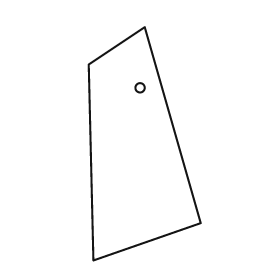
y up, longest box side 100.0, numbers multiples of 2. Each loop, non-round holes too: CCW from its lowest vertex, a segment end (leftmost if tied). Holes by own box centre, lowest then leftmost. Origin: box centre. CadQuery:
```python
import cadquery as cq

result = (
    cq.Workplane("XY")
    .moveTo(-22.0, -50.0)
    .lineTo(24.0, -34.0)
    .lineTo(0.0, 50.0)
    .lineTo(-24.0, 34.0)
    .close()
    .moveTo(-2.0, 24.0)
    .circle(2.0)
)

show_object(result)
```